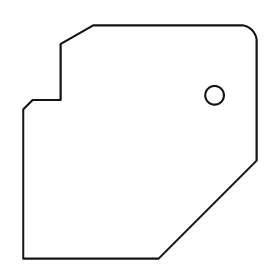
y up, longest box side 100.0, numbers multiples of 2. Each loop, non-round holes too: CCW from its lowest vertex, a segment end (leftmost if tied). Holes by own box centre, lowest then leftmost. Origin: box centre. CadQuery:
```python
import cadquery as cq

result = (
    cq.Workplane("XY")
    .moveTo(-50.0, -50.0)
    .lineTo(8.0, -50.0)
    .lineTo(50.0, -8.0)
    .lineTo(50.0, 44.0)
    .threePointArc((48.0, 48.0), (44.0, 50.0))
    .lineTo(-20.0, 50.0)
    .lineTo(-34.0, 42.0)
    .lineTo(-34.0, 18.0)
    .lineTo(-46.0, 18.0)
    .lineTo(-50.0, 14.0)
    .close()
    .moveTo(32.0, 20.0)
    .circle(4.0)
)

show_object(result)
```